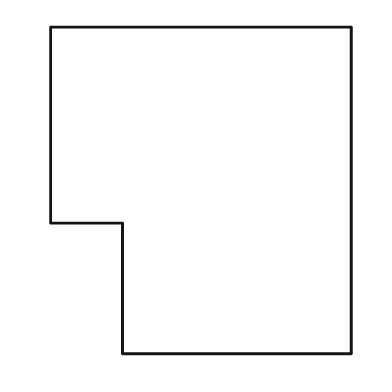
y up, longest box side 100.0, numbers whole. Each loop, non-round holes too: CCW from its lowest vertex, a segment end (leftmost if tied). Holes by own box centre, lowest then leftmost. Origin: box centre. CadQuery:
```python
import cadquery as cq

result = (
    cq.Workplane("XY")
    .moveTo(-24.0, -50.0)
    .lineTo(46.0, -50.0)
    .lineTo(46.0, 50.0)
    .lineTo(-46.0, 50.0)
    .lineTo(-46.0, -10.0)
    .lineTo(-24.0, -10.0)
    .close()
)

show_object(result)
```